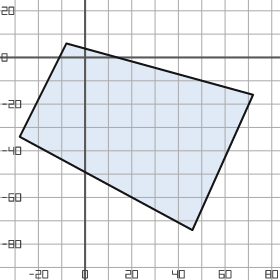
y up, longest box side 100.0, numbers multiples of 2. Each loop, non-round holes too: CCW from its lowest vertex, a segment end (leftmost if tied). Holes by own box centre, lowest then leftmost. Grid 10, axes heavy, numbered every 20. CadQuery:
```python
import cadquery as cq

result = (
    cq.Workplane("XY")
    .moveTo(46.0, -74.0)
    .lineTo(72.0, -16.0)
    .lineTo(-8.0, 6.0)
    .lineTo(-28.0, -34.0)
    .close()
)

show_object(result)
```